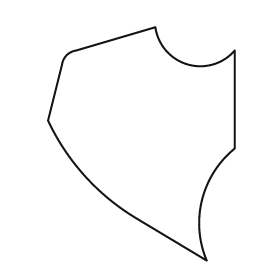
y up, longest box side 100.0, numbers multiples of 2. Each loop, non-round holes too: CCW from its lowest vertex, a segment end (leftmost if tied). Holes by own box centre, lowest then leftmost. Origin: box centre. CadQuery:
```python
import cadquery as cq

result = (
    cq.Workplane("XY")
    .moveTo(28.0, -50.0)
    .threePointArc((26.0, -24.0), (40.0, -2.0))
    .lineTo(40.0, 40.0)
    .threePointArc((20.0, 34.0), (6.0, 50.0))
    .lineTo(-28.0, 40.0)
    .threePointArc((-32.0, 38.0), (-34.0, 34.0))
    .lineTo(-40.0, 10.0)
    .threePointArc((-24.0, -14.0), (-2.0, -32.0))
    .close()
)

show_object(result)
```